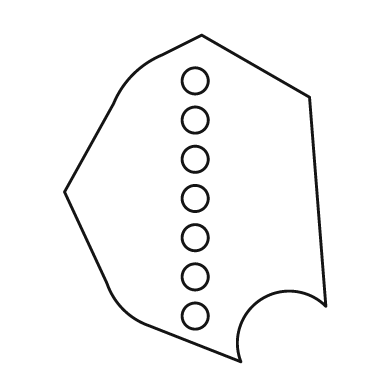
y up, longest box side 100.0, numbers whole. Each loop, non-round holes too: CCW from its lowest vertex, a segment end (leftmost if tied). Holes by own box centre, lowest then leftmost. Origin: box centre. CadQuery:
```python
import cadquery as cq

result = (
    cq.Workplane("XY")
    .moveTo(14.0, -50.0)
    .threePointArc((20.0, -31.0), (40.0, -33.0))
    .lineTo(35.0, 31.0)
    .lineTo(2.0, 50.0)
    .lineTo(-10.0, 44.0)
    .threePointArc((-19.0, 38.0), (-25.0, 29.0))
    .lineTo(-40.0, 2.0)
    .lineTo(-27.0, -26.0)
    .threePointArc((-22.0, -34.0), (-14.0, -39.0))
    .close()
    .moveTo(0.0, -36.0)
    .circle(4.0)
    .moveTo(0.0, -24.0)
    .circle(4.0)
    .moveTo(0.0, -12.0)
    .circle(4.0)
    .moveTo(0.0, 0.0)
    .circle(4.0)
    .moveTo(0.0, 12.0)
    .circle(4.0)
    .moveTo(0.0, 24.0)
    .circle(4.0)
    .moveTo(0.0, 36.0)
    .circle(4.0)
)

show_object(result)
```